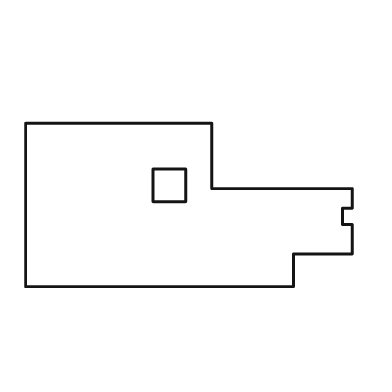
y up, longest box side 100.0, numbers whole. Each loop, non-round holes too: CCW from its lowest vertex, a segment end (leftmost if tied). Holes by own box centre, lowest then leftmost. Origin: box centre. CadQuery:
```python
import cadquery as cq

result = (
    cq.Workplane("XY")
    .moveTo(-50.0, -25.0)
    .lineTo(32.0, -25.0)
    .lineTo(32.0, -15.0)
    .lineTo(50.0, -15.0)
    .lineTo(50.0, -6.0)
    .lineTo(47.0, -6.0)
    .lineTo(47.0, -1.0)
    .lineTo(50.0, -1.0)
    .lineTo(50.0, 5.0)
    .lineTo(7.0, 5.0)
    .lineTo(7.0, 25.0)
    .lineTo(-50.0, 25.0)
    .close()
    .moveTo(-11.0, 1.0)
    .lineTo(-1.0, 1.0)
    .lineTo(-1.0, 11.0)
    .lineTo(-11.0, 11.0)
    .close()
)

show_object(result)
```